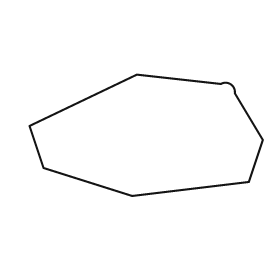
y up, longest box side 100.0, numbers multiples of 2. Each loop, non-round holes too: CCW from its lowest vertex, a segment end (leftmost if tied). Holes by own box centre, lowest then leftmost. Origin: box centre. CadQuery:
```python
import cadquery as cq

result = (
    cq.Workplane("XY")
    .moveTo(-6.0, -26.0)
    .lineTo(44.0, -20.0)
    .lineTo(50.0, -2.0)
    .lineTo(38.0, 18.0)
    .threePointArc((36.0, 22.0), (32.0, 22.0))
    .lineTo(-4.0, 26.0)
    .lineTo(-50.0, 4.0)
    .lineTo(-44.0, -14.0)
    .close()
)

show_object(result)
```